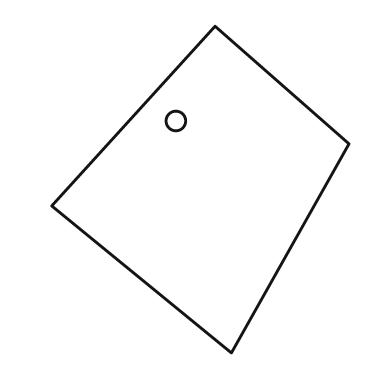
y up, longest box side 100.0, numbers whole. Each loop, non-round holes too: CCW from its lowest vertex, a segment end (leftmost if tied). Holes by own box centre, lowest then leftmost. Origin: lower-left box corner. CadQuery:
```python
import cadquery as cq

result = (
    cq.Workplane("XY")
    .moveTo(55.0, 0.0)
    .lineTo(91.0, 64.0)
    .lineTo(50.0, 100.0)
    .lineTo(0.0, 45.0)
    .close()
    .moveTo(38.0, 71.0)
    .circle(3.0)
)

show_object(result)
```